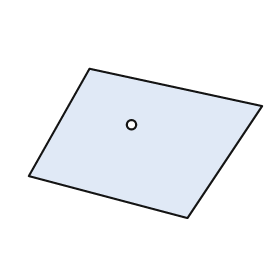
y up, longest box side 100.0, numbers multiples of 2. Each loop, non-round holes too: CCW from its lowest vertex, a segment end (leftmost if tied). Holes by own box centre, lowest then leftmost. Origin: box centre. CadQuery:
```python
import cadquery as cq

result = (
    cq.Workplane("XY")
    .moveTo(18.0, -32.0)
    .lineTo(50.0, 16.0)
    .lineTo(-24.0, 32.0)
    .lineTo(-50.0, -14.0)
    .close()
    .moveTo(-6.0, 8.0)
    .circle(2.0)
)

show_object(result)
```